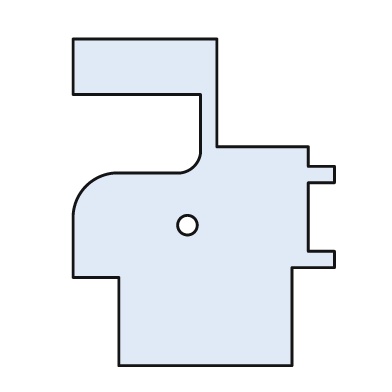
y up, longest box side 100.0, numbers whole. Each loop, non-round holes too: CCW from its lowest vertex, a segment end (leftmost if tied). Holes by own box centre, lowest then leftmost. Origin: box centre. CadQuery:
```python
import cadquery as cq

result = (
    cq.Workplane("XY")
    .moveTo(-26.0, -50.0)
    .lineTo(27.0, -50.0)
    .lineTo(27.0, -20.0)
    .lineTo(40.0, -20.0)
    .lineTo(40.0, -15.0)
    .lineTo(32.0, -15.0)
    .lineTo(32.0, 6.0)
    .lineTo(40.0, 6.0)
    .lineTo(40.0, 11.0)
    .lineTo(32.0, 11.0)
    .lineTo(32.0, 17.0)
    .lineTo(4.0, 17.0)
    .lineTo(4.0, 50.0)
    .lineTo(-40.0, 50.0)
    .lineTo(-40.0, 33.0)
    .lineTo(-1.0, 33.0)
    .lineTo(-1.0, 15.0)
    .threePointArc((-3.0, 11.0), (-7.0, 9.0))
    .lineTo(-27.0, 9.0)
    .threePointArc((-36.0, 5.0), (-40.0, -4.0))
    .lineTo(-40.0, -23.0)
    .lineTo(-26.0, -23.0)
    .close()
    .moveTo(-5.0, -7.0)
    .circle(3.0)
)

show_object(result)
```